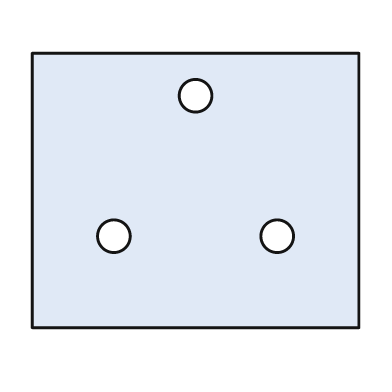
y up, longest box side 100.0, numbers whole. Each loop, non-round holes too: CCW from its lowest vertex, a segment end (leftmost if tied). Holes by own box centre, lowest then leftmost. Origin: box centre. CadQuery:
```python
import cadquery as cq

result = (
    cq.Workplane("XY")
    .moveTo(-50.0, -42.0)
    .lineTo(50.0, -42.0)
    .lineTo(50.0, 42.0)
    .lineTo(-50.0, 42.0)
    .close()
    .moveTo(-25.0, -14.0)
    .circle(5.0)
    .moveTo(25.0, -14.0)
    .circle(5.0)
    .moveTo(0.0, 29.0)
    .circle(5.0)
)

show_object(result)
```